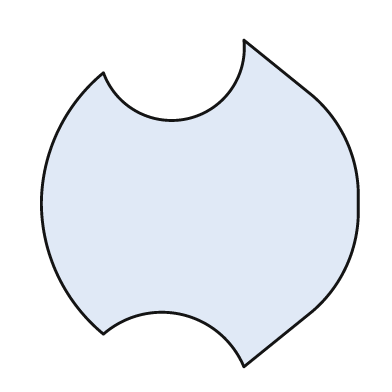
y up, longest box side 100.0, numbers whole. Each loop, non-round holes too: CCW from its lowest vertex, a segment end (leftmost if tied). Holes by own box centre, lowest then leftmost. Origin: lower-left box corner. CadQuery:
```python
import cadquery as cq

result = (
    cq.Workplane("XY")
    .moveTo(62.0, 0.0)
    .lineTo(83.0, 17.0)
    .threePointArc((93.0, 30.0), (97.0, 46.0))
    .lineTo(97.0, 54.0)
    .threePointArc((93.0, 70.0), (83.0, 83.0))
    .lineTo(62.0, 100.0)
    .threePointArc((45.0, 76.0), (19.0, 90.0))
    .threePointArc((5.0, 72.0), (0.0, 50.0))
    .threePointArc((5.0, 28.0), (19.0, 10.0))
    .threePointArc((43.0, 16.0), (62.0, 0.0))
    .close()
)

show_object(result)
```